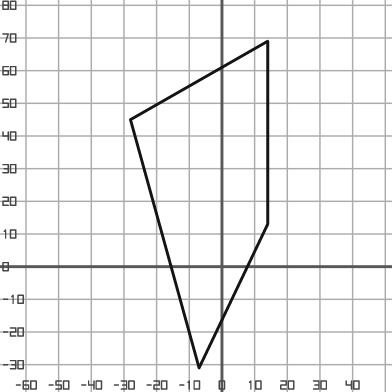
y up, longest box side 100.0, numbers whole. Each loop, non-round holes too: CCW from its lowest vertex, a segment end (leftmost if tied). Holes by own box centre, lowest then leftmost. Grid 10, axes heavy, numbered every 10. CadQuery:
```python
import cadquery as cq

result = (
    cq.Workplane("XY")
    .moveTo(-7.0, -31.0)
    .lineTo(14.0, 13.0)
    .lineTo(14.0, 69.0)
    .lineTo(-28.0, 45.0)
    .close()
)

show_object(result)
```